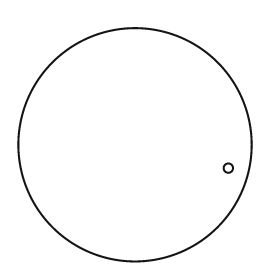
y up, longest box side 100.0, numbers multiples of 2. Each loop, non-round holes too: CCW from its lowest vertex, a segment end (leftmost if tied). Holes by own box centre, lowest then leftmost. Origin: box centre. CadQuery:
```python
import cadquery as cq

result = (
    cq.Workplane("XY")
    .moveTo(0.0, 0.0)
    .circle(50.0)
    .moveTo(40.0, -10.0)
    .circle(2.0)
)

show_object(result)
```